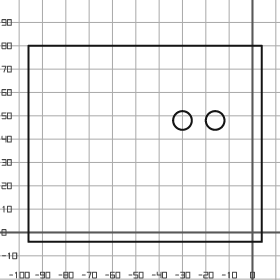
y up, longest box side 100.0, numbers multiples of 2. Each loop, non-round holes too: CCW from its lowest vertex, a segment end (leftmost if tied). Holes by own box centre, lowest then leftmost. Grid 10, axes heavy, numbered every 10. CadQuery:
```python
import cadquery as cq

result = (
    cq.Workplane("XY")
    .moveTo(-96.0, -4.0)
    .lineTo(4.0, -4.0)
    .lineTo(4.0, 80.0)
    .lineTo(-96.0, 80.0)
    .close()
    .moveTo(-30.0, 48.0)
    .circle(4.0)
    .moveTo(-16.0, 48.0)
    .circle(4.0)
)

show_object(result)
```